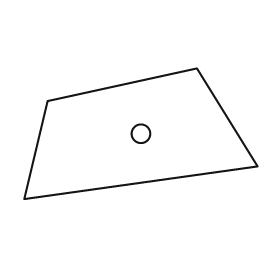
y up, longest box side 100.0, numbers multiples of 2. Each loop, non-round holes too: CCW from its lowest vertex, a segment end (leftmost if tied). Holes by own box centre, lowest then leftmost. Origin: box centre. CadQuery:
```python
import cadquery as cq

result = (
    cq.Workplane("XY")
    .moveTo(-50.0, -28.0)
    .lineTo(50.0, -14.0)
    .lineTo(24.0, 28.0)
    .lineTo(-40.0, 14.0)
    .close()
    .moveTo(0.0, 0.0)
    .circle(4.0)
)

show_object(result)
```